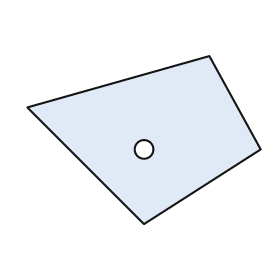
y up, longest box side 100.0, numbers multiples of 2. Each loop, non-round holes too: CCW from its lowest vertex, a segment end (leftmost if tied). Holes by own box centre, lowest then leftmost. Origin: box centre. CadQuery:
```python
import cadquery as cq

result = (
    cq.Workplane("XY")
    .moveTo(0.0, -36.0)
    .lineTo(50.0, -4.0)
    .lineTo(28.0, 36.0)
    .lineTo(-50.0, 14.0)
    .close()
    .moveTo(0.0, -4.0)
    .circle(4.0)
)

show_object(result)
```